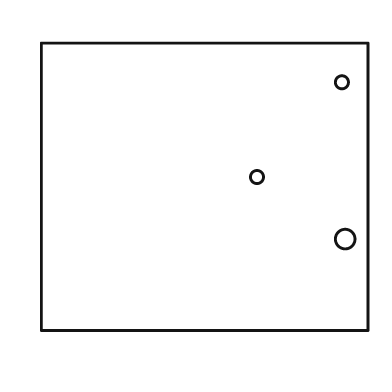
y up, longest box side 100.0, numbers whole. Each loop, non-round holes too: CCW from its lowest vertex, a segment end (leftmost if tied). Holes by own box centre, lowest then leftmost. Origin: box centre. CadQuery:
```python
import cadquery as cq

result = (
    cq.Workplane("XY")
    .moveTo(-50.0, -44.0)
    .lineTo(50.0, -44.0)
    .lineTo(50.0, 44.0)
    .lineTo(-50.0, 44.0)
    .close()
    .moveTo(43.0, -16.0)
    .circle(3.0)
    .moveTo(16.0, 3.0)
    .circle(2.0)
    .moveTo(42.0, 32.0)
    .circle(2.0)
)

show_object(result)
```